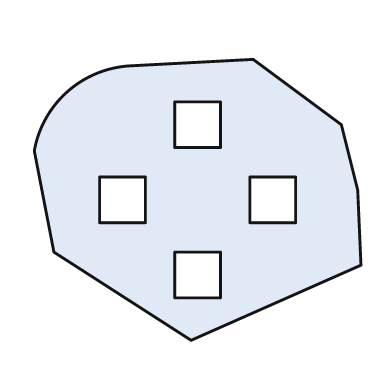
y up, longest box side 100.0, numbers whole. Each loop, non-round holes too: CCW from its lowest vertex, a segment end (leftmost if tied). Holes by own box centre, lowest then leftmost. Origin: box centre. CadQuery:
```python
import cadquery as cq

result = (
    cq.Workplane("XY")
    .moveTo(-2.0, -43.0)
    .lineTo(50.0, -20.0)
    .lineTo(49.0, 3.0)
    .lineTo(44.0, 23.0)
    .lineTo(17.0, 43.0)
    .lineTo(-21.0, 41.0)
    .threePointArc((-40.0, 33.0), (-50.0, 15.0))
    .lineTo(-44.0, -16.0)
    .close()
    .moveTo(-7.0, -30.0)
    .lineTo(7.0, -30.0)
    .lineTo(7.0, -16.0)
    .lineTo(-7.0, -16.0)
    .close()
    .moveTo(-30.0, -7.0)
    .lineTo(-16.0, -7.0)
    .lineTo(-16.0, 7.0)
    .lineTo(-30.0, 7.0)
    .close()
    .moveTo(16.0, -7.0)
    .lineTo(30.0, -7.0)
    .lineTo(30.0, 7.0)
    .lineTo(16.0, 7.0)
    .close()
    .moveTo(-7.0, 16.0)
    .lineTo(7.0, 16.0)
    .lineTo(7.0, 30.0)
    .lineTo(-7.0, 30.0)
    .close()
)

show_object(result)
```